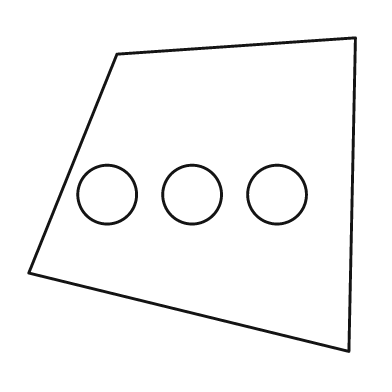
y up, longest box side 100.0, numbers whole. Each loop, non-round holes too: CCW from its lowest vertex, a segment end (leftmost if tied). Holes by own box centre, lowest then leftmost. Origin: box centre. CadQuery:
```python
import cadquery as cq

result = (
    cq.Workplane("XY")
    .moveTo(48.0, -48.0)
    .lineTo(50.0, 48.0)
    .lineTo(-23.0, 43.0)
    .lineTo(-50.0, -24.0)
    .close()
    .moveTo(-26.0, 0.0)
    .circle(9.0)
    .moveTo(0.0, 0.0)
    .circle(9.0)
    .moveTo(26.0, 0.0)
    .circle(9.0)
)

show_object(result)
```